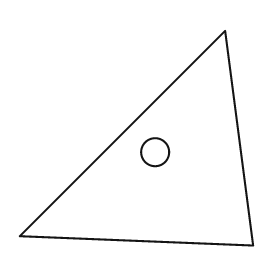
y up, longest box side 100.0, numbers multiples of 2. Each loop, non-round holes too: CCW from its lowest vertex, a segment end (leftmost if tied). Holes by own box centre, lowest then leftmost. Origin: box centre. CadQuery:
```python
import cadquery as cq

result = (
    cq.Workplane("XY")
    .moveTo(50.0, -46.0)
    .lineTo(38.0, 46.0)
    .lineTo(-50.0, -42.0)
    .close()
    .moveTo(8.0, -6.0)
    .circle(6.0)
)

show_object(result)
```